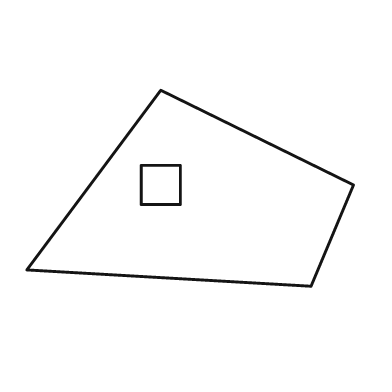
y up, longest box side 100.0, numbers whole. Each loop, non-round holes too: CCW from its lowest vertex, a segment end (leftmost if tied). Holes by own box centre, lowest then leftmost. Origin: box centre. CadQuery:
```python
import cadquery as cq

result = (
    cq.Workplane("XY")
    .moveTo(37.0, -30.0)
    .lineTo(50.0, 1.0)
    .lineTo(-9.0, 30.0)
    .lineTo(-50.0, -25.0)
    .close()
    .moveTo(-15.0, -5.0)
    .lineTo(-3.0, -5.0)
    .lineTo(-3.0, 7.0)
    .lineTo(-15.0, 7.0)
    .close()
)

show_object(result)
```